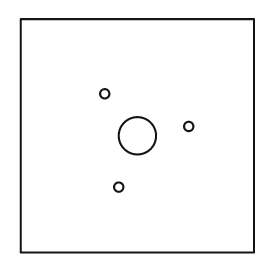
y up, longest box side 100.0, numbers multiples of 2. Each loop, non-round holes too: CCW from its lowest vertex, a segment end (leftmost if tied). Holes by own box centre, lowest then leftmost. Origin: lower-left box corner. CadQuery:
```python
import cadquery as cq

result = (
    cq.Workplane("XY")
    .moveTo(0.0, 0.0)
    .lineTo(100.0, 0.0)
    .lineTo(100.0, 100.0)
    .lineTo(0.0, 100.0)
    .close()
    .moveTo(42.0, 28.0)
    .circle(2.0)
    .moveTo(50.0, 50.0)
    .circle(8.0)
    .moveTo(72.0, 54.0)
    .circle(2.0)
    .moveTo(36.0, 68.0)
    .circle(2.0)
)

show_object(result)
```